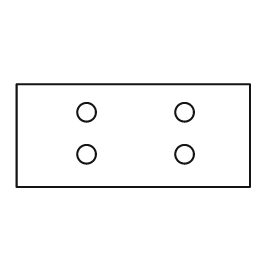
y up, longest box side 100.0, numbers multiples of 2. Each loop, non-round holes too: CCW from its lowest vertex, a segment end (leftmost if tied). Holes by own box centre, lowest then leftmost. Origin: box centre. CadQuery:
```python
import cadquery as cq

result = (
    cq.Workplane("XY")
    .moveTo(-50.0, -22.0)
    .lineTo(50.0, -22.0)
    .lineTo(50.0, 22.0)
    .lineTo(-50.0, 22.0)
    .close()
    .moveTo(-20.0, -8.0)
    .circle(4.0)
    .moveTo(22.0, -8.0)
    .circle(4.0)
    .moveTo(-20.0, 10.0)
    .circle(4.0)
    .moveTo(22.0, 10.0)
    .circle(4.0)
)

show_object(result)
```